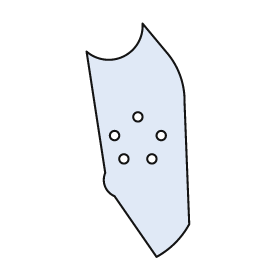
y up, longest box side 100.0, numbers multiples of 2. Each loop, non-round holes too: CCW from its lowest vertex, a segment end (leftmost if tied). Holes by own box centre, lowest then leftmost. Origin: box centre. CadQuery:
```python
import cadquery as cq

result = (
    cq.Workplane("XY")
    .moveTo(8.0, -50.0)
    .threePointArc((16.0, -44.0), (22.0, -36.0))
    .lineTo(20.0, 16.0)
    .threePointArc((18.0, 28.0), (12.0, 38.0))
    .lineTo(2.0, 50.0)
    .threePointArc((-6.0, 36.0), (-22.0, 38.0))
    .lineTo(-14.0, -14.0)
    .threePointArc((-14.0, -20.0), (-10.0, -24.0))
    .close()
    .moveTo(-6.0, -8.0)
    .circle(2.0)
    .moveTo(6.0, -8.0)
    .circle(2.0)
    .moveTo(-10.0, 2.0)
    .circle(2.0)
    .moveTo(10.0, 2.0)
    .circle(2.0)
    .moveTo(0.0, 10.0)
    .circle(2.0)
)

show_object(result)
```